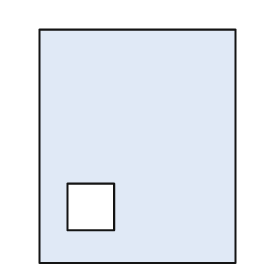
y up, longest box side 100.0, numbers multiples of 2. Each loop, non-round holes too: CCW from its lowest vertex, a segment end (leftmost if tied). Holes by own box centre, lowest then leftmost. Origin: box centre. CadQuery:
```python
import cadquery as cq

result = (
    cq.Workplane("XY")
    .moveTo(-42.0, -50.0)
    .lineTo(42.0, -50.0)
    .lineTo(42.0, 50.0)
    .lineTo(-42.0, 50.0)
    .close()
    .moveTo(-30.0, -36.0)
    .lineTo(-10.0, -36.0)
    .lineTo(-10.0, -16.0)
    .lineTo(-30.0, -16.0)
    .close()
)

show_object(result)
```